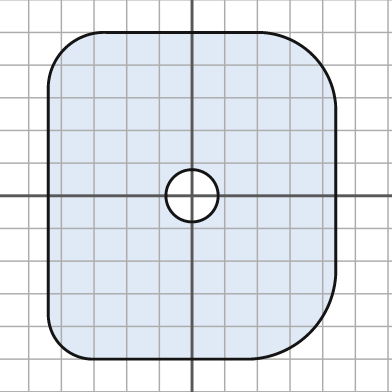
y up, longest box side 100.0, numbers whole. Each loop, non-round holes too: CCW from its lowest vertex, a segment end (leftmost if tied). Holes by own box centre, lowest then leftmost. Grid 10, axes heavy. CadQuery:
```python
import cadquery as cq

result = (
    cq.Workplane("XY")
    .moveTo(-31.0, -50.0)
    .lineTo(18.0, -50.0)
    .threePointArc((36.0, -42.0), (44.0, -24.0))
    .lineTo(44.0, 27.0)
    .threePointArc((37.0, 43.0), (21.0, 50.0))
    .lineTo(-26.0, 50.0)
    .threePointArc((-39.0, 45.0), (-44.0, 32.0))
    .lineTo(-44.0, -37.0)
    .threePointArc((-40.0, -46.0), (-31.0, -50.0))
    .close()
    .moveTo(0.0, 0.0)
    .circle(8.0)
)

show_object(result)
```